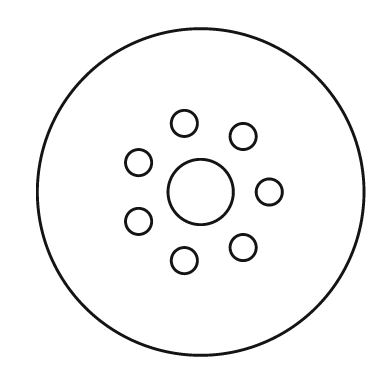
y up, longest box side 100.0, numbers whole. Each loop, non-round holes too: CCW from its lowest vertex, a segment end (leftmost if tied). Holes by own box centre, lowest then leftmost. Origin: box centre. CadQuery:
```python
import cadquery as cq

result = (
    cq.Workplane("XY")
    .moveTo(0.0, 0.0)
    .circle(50.0)
    .moveTo(-5.0, -21.0)
    .circle(4.0)
    .moveTo(13.0, -17.0)
    .circle(4.0)
    .moveTo(-19.0, -9.0)
    .circle(4.0)
    .moveTo(0.0, 0.0)
    .circle(10.0)
    .moveTo(21.0, 0.0)
    .circle(4.0)
    .moveTo(-19.0, 9.0)
    .circle(4.0)
    .moveTo(13.0, 17.0)
    .circle(4.0)
    .moveTo(-5.0, 21.0)
    .circle(4.0)
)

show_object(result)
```